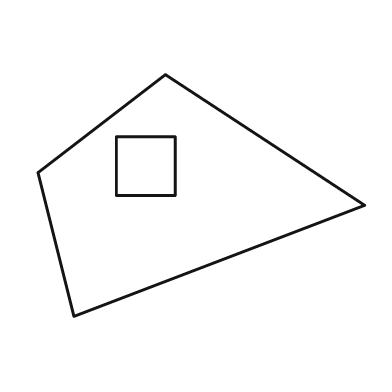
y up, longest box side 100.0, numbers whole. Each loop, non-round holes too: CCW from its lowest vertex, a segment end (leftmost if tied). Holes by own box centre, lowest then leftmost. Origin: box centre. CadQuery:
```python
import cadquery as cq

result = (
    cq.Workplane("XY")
    .moveTo(-39.0, -37.0)
    .lineTo(50.0, -3.0)
    .lineTo(-11.0, 37.0)
    .lineTo(-50.0, 7.0)
    .close()
    .moveTo(-26.0, 0.0)
    .lineTo(-8.0, 0.0)
    .lineTo(-8.0, 18.0)
    .lineTo(-26.0, 18.0)
    .close()
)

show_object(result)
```